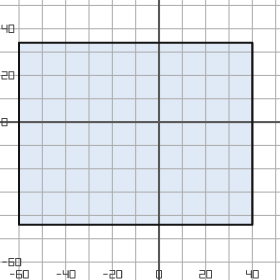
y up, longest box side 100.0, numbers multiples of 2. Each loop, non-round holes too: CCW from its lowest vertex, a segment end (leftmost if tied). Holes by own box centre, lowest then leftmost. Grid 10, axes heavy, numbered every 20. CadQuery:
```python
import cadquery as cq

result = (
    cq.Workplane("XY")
    .moveTo(-60.0, -44.0)
    .lineTo(40.0, -44.0)
    .lineTo(40.0, 34.0)
    .lineTo(-60.0, 34.0)
    .close()
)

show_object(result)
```